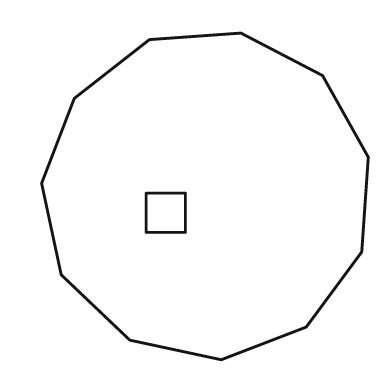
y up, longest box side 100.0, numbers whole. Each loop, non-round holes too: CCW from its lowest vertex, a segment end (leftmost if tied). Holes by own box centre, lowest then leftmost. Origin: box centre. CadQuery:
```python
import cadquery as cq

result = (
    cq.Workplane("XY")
    .moveTo(5.0, -50.0)
    .lineTo(31.0, -40.0)
    .lineTo(48.0, -17.0)
    .lineTo(50.0, 12.0)
    .lineTo(36.0, 37.0)
    .lineTo(11.0, 50.0)
    .lineTo(-17.0, 48.0)
    .lineTo(-40.0, 30.0)
    .lineTo(-50.0, 4.0)
    .lineTo(-44.0, -24.0)
    .lineTo(-23.0, -44.0)
    .close()
    .moveTo(-18.0, -11.0)
    .lineTo(-6.0, -11.0)
    .lineTo(-6.0, 1.0)
    .lineTo(-18.0, 1.0)
    .close()
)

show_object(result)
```